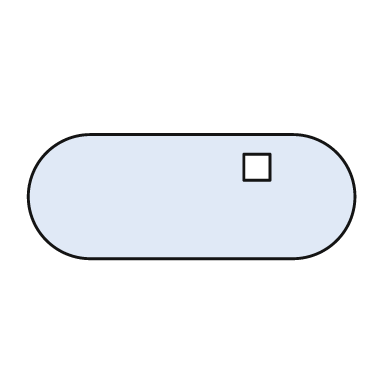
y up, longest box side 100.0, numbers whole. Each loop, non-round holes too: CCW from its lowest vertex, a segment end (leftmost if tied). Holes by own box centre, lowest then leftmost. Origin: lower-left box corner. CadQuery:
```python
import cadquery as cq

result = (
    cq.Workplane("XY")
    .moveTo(19.0, 0.0)
    .lineTo(81.0, 0.0)
    .threePointArc((100.0, 19.0), (81.0, 38.0))
    .lineTo(19.0, 38.0)
    .threePointArc((0.0, 19.0), (19.0, 0.0))
    .close()
    .moveTo(66.0, 24.0)
    .lineTo(74.0, 24.0)
    .lineTo(74.0, 32.0)
    .lineTo(66.0, 32.0)
    .close()
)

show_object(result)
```